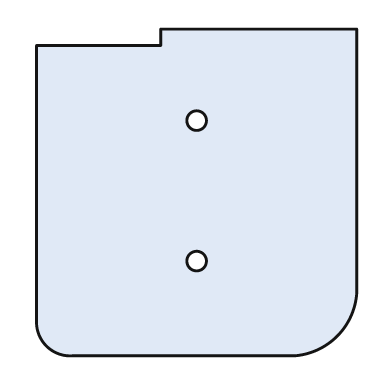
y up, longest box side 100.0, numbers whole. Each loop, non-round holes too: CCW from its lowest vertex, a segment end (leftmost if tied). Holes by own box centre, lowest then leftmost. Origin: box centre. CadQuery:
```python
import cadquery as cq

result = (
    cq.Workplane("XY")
    .moveTo(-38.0, -50.0)
    .lineTo(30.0, -50.0)
    .threePointArc((43.0, -44.0), (49.0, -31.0))
    .lineTo(49.0, 50.0)
    .lineTo(-11.0, 50.0)
    .lineTo(-11.0, 45.0)
    .lineTo(-49.0, 45.0)
    .lineTo(-49.0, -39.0)
    .threePointArc((-46.0, -47.0), (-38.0, -50.0))
    .close()
    .moveTo(0.0, -21.0)
    .circle(3.0)
    .moveTo(0.0, 22.0)
    .circle(3.0)
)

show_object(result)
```